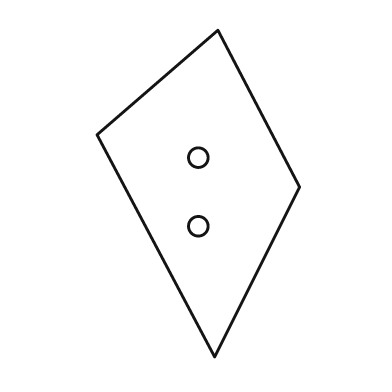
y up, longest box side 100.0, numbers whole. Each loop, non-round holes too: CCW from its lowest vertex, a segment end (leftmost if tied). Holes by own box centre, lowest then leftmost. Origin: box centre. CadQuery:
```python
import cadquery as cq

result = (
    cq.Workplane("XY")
    .moveTo(5.0, -50.0)
    .lineTo(31.0, 2.0)
    .lineTo(6.0, 50.0)
    .lineTo(-31.0, 18.0)
    .close()
    .moveTo(0.0, -10.0)
    .circle(3.0)
    .moveTo(0.0, 11.0)
    .circle(3.0)
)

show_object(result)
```